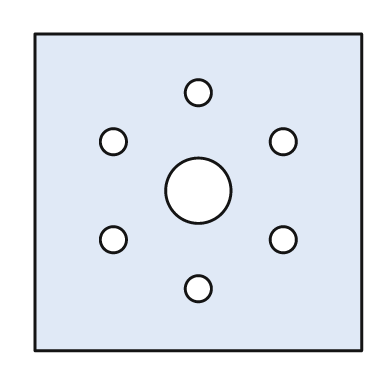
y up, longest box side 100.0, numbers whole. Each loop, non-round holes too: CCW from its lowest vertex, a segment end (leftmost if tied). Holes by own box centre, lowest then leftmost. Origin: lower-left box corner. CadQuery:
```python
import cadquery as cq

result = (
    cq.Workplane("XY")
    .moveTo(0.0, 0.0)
    .lineTo(100.0, 0.0)
    .lineTo(100.0, 97.0)
    .lineTo(0.0, 97.0)
    .close()
    .moveTo(50.0, 19.0)
    .circle(4.0)
    .moveTo(24.0, 34.0)
    .circle(4.0)
    .moveTo(76.0, 34.0)
    .circle(4.0)
    .moveTo(50.0, 49.0)
    .circle(10.0)
    .moveTo(24.0, 64.0)
    .circle(4.0)
    .moveTo(76.0, 64.0)
    .circle(4.0)
    .moveTo(50.0, 79.0)
    .circle(4.0)
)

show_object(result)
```